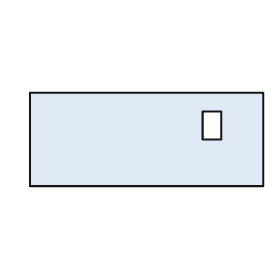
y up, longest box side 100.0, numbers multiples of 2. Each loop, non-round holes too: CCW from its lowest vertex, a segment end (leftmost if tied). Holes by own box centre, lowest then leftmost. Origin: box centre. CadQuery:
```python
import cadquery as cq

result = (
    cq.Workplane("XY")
    .moveTo(-50.0, -20.0)
    .lineTo(50.0, -20.0)
    .lineTo(50.0, 20.0)
    .lineTo(-50.0, 20.0)
    .close()
    .moveTo(24.0, 0.0)
    .lineTo(32.0, 0.0)
    .lineTo(32.0, 12.0)
    .lineTo(24.0, 12.0)
    .close()
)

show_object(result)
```